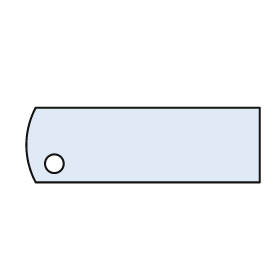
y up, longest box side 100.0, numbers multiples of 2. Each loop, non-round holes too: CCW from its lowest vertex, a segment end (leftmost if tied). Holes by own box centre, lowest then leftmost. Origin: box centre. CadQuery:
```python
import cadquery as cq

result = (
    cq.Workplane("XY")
    .moveTo(-46.0, -16.0)
    .lineTo(50.0, -16.0)
    .lineTo(50.0, 16.0)
    .lineTo(-46.0, 16.0)
    .threePointArc((-50.0, 0.0), (-46.0, -16.0))
    .close()
    .moveTo(-38.0, -8.0)
    .circle(4.0)
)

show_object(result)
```